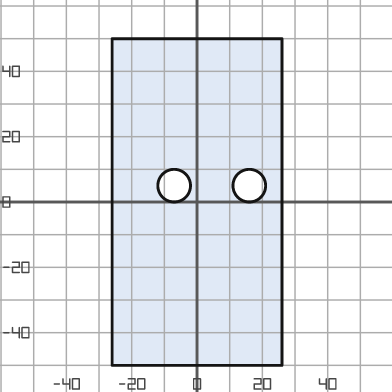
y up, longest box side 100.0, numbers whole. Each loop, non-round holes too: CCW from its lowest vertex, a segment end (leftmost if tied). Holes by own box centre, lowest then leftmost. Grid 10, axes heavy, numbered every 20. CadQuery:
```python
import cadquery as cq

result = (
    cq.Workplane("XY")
    .moveTo(-26.0, -50.0)
    .lineTo(26.0, -50.0)
    .lineTo(26.0, 50.0)
    .lineTo(-26.0, 50.0)
    .close()
    .moveTo(-7.0, 5.0)
    .circle(5.0)
    .moveTo(16.0, 5.0)
    .circle(5.0)
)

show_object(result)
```